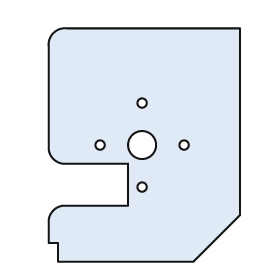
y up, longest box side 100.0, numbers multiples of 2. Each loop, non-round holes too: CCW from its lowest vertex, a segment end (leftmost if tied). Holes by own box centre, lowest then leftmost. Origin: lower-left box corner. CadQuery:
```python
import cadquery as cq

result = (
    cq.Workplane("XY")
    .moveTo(4.0, 0.0)
    .lineTo(62.0, 0.0)
    .lineTo(82.0, 20.0)
    .lineTo(82.0, 100.0)
    .lineTo(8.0, 100.0)
    .threePointArc((2.0, 98.0), (0.0, 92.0))
    .lineTo(0.0, 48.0)
    .threePointArc((2.0, 44.0), (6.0, 42.0))
    .lineTo(34.0, 42.0)
    .lineTo(34.0, 24.0)
    .lineTo(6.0, 24.0)
    .threePointArc((2.0, 22.0), (0.0, 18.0))
    .lineTo(0.0, 8.0)
    .lineTo(4.0, 8.0)
    .close()
    .moveTo(40.0, 32.0)
    .circle(2.0)
    .moveTo(22.0, 50.0)
    .circle(2.0)
    .moveTo(40.0, 50.0)
    .circle(6.0)
    .moveTo(58.0, 50.0)
    .circle(2.0)
    .moveTo(40.0, 68.0)
    .circle(2.0)
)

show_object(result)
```